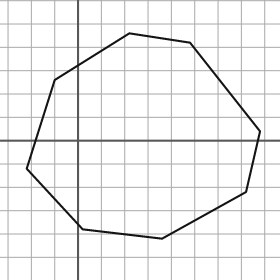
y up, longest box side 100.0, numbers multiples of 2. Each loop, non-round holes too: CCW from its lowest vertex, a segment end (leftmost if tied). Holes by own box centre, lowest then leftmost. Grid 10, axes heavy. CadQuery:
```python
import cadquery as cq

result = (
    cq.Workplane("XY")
    .moveTo(36.0, -42.0)
    .lineTo(72.0, -22.0)
    .lineTo(78.0, 4.0)
    .lineTo(48.0, 42.0)
    .lineTo(22.0, 46.0)
    .lineTo(-10.0, 26.0)
    .lineTo(-22.0, -12.0)
    .lineTo(2.0, -38.0)
    .close()
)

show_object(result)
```